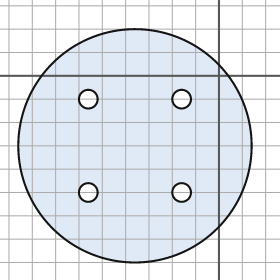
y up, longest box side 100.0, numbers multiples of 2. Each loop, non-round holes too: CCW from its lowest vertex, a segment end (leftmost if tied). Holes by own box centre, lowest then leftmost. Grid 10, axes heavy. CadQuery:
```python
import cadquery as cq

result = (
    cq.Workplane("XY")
    .moveTo(-36.0, -30.0)
    .circle(50.0)
    .moveTo(-56.0, -50.0)
    .circle(4.0)
    .moveTo(-16.0, -50.0)
    .circle(4.0)
    .moveTo(-56.0, -10.0)
    .circle(4.0)
    .moveTo(-16.0, -10.0)
    .circle(4.0)
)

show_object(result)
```